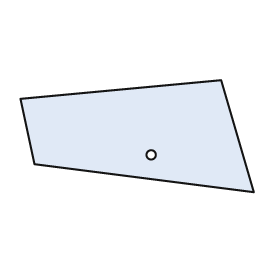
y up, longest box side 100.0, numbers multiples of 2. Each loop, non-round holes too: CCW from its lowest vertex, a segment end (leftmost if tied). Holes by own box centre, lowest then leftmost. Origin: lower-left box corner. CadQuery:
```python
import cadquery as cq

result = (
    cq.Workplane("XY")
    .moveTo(100.0, 0.0)
    .lineTo(86.0, 48.0)
    .lineTo(0.0, 40.0)
    .lineTo(6.0, 12.0)
    .close()
    .moveTo(56.0, 16.0)
    .circle(2.0)
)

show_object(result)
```